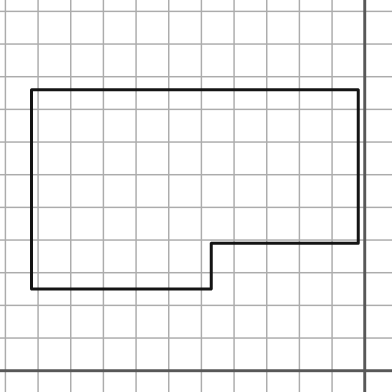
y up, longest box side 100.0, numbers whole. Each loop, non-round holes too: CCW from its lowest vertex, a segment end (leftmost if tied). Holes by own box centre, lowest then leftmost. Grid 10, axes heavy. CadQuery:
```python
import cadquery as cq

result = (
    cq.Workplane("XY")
    .moveTo(-102.0, 25.0)
    .lineTo(-47.0, 25.0)
    .lineTo(-47.0, 39.0)
    .lineTo(-2.0, 39.0)
    .lineTo(-2.0, 86.0)
    .lineTo(-102.0, 86.0)
    .close()
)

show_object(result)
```